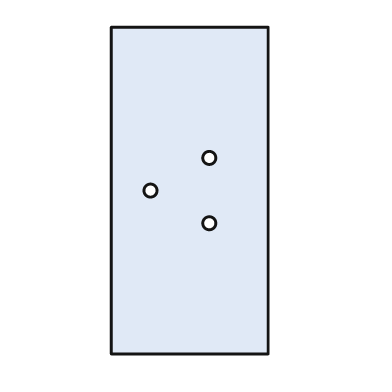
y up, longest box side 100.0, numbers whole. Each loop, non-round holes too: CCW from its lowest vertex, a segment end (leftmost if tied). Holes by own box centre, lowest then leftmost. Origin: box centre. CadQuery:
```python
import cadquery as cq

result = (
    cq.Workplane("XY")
    .moveTo(-24.0, -50.0)
    .lineTo(24.0, -50.0)
    .lineTo(24.0, 50.0)
    .lineTo(-24.0, 50.0)
    .close()
    .moveTo(6.0, -10.0)
    .circle(2.0)
    .moveTo(-12.0, 0.0)
    .circle(2.0)
    .moveTo(6.0, 10.0)
    .circle(2.0)
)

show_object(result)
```